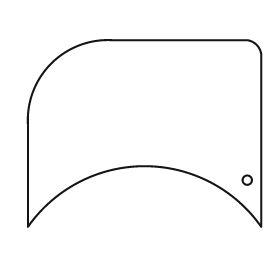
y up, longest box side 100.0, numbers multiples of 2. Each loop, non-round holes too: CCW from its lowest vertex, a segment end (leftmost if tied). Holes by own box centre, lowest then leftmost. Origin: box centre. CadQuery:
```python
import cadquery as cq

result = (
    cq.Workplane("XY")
    .moveTo(-50.0, -40.0)
    .threePointArc((0.0, -14.0), (50.0, -40.0))
    .lineTo(50.0, 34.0)
    .threePointArc((48.0, 38.0), (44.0, 40.0))
    .lineTo(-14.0, 40.0)
    .threePointArc((-40.0, 30.0), (-50.0, 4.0))
    .close()
    .moveTo(44.0, -20.0)
    .circle(2.0)
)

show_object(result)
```